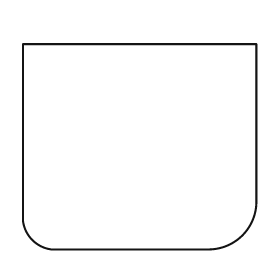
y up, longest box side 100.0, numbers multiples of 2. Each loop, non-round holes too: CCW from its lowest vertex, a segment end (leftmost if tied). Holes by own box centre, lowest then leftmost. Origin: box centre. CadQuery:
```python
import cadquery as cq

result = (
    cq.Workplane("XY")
    .moveTo(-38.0, -44.0)
    .lineTo(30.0, -44.0)
    .threePointArc((44.0, -38.0), (50.0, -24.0))
    .lineTo(50.0, 44.0)
    .lineTo(-50.0, 44.0)
    .lineTo(-50.0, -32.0)
    .threePointArc((-46.0, -40.0), (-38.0, -44.0))
    .close()
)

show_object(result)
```